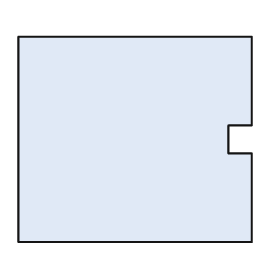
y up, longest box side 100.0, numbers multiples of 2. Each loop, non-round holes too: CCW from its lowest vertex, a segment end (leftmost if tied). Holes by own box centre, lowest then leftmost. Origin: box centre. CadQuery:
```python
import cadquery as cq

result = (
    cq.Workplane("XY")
    .moveTo(-50.0, -44.0)
    .lineTo(50.0, -44.0)
    .lineTo(50.0, -6.0)
    .lineTo(40.0, -6.0)
    .lineTo(40.0, 6.0)
    .lineTo(50.0, 6.0)
    .lineTo(50.0, 44.0)
    .lineTo(-50.0, 44.0)
    .close()
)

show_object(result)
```